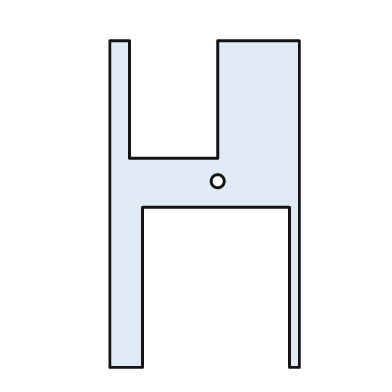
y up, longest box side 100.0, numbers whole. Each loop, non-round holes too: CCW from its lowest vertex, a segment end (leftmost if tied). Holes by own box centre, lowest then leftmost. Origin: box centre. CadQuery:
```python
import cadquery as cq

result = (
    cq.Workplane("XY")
    .moveTo(-29.0, -50.0)
    .lineTo(-19.0, -50.0)
    .lineTo(-19.0, -1.0)
    .lineTo(26.0, -1.0)
    .lineTo(26.0, -50.0)
    .lineTo(29.0, -50.0)
    .lineTo(29.0, 50.0)
    .lineTo(4.0, 50.0)
    .lineTo(4.0, 14.0)
    .lineTo(-23.0, 14.0)
    .lineTo(-23.0, 50.0)
    .lineTo(-29.0, 50.0)
    .close()
    .moveTo(4.0, 7.0)
    .circle(2.0)
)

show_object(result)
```